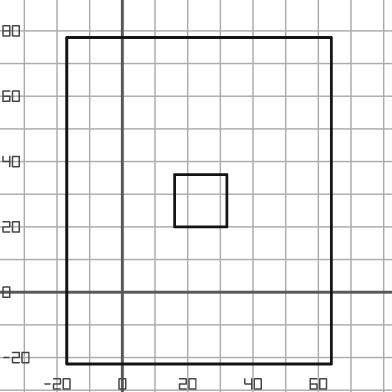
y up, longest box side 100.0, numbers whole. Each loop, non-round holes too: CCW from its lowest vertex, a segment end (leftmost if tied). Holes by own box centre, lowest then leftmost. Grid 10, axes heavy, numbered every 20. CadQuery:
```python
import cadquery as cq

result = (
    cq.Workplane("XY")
    .moveTo(-17.0, -22.0)
    .lineTo(64.0, -22.0)
    .lineTo(64.0, 78.0)
    .lineTo(-17.0, 78.0)
    .close()
    .moveTo(16.0, 20.0)
    .lineTo(32.0, 20.0)
    .lineTo(32.0, 36.0)
    .lineTo(16.0, 36.0)
    .close()
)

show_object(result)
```